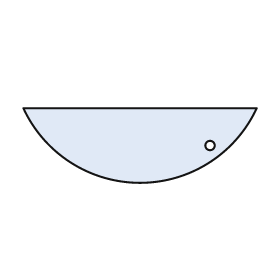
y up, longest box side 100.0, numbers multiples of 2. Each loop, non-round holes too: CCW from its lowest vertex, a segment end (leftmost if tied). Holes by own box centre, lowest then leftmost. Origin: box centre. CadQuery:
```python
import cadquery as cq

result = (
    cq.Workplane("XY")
    .moveTo(-50.0, 16.0)
    .threePointArc((0.0, -16.0), (50.0, 16.0))
    .close()
    .moveTo(30.0, 0.0)
    .circle(2.0)
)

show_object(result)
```